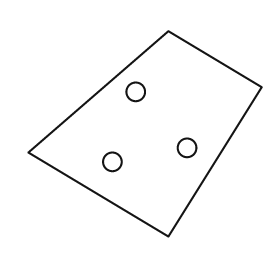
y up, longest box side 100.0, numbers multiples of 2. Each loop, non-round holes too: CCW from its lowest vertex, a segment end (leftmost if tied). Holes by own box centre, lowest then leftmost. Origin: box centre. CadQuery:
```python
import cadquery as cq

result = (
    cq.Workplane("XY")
    .moveTo(10.0, -44.0)
    .lineTo(50.0, 20.0)
    .lineTo(10.0, 44.0)
    .lineTo(-50.0, -8.0)
    .close()
    .moveTo(-14.0, -12.0)
    .circle(4.0)
    .moveTo(18.0, -6.0)
    .circle(4.0)
    .moveTo(-4.0, 18.0)
    .circle(4.0)
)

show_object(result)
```